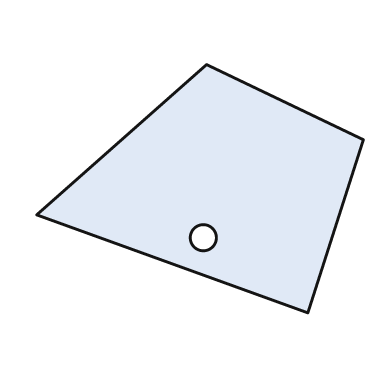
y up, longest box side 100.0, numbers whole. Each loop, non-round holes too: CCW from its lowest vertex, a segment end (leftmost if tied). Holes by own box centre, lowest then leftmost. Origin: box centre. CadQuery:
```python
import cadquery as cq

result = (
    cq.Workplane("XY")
    .moveTo(33.0, -38.0)
    .lineTo(50.0, 15.0)
    .lineTo(2.0, 38.0)
    .lineTo(-50.0, -8.0)
    .close()
    .moveTo(1.0, -15.0)
    .circle(4.0)
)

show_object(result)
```